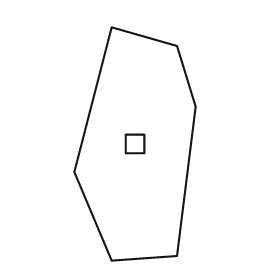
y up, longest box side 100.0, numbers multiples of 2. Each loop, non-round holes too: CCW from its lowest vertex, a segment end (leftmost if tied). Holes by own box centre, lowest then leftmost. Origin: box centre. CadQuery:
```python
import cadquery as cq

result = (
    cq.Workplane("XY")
    .moveTo(-10.0, -50.0)
    .lineTo(18.0, -48.0)
    .lineTo(26.0, 16.0)
    .lineTo(18.0, 42.0)
    .lineTo(-10.0, 50.0)
    .lineTo(-26.0, -12.0)
    .close()
    .moveTo(-4.0, -4.0)
    .lineTo(4.0, -4.0)
    .lineTo(4.0, 4.0)
    .lineTo(-4.0, 4.0)
    .close()
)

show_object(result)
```